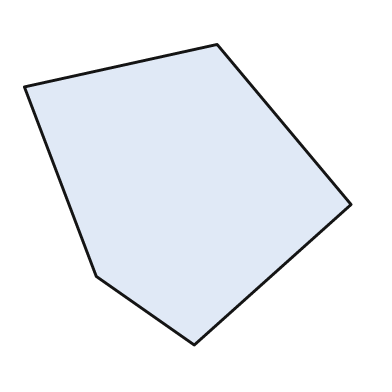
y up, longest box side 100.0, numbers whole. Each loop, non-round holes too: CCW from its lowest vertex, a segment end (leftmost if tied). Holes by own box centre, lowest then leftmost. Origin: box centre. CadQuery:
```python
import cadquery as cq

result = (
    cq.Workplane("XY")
    .moveTo(2.0, -46.0)
    .lineTo(50.0, -3.0)
    .lineTo(9.0, 46.0)
    .lineTo(-50.0, 33.0)
    .lineTo(-28.0, -25.0)
    .close()
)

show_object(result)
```